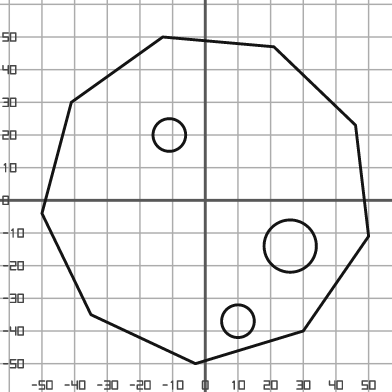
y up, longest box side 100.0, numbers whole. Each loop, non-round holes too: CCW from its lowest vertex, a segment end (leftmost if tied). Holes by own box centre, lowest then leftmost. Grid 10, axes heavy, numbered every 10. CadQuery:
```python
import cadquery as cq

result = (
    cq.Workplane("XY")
    .moveTo(-3.0, -50.0)
    .lineTo(30.0, -40.0)
    .lineTo(50.0, -11.0)
    .lineTo(46.0, 23.0)
    .lineTo(21.0, 47.0)
    .lineTo(-13.0, 50.0)
    .lineTo(-41.0, 30.0)
    .lineTo(-50.0, -4.0)
    .lineTo(-35.0, -35.0)
    .close()
    .moveTo(10.0, -37.0)
    .circle(5.0)
    .moveTo(26.0, -14.0)
    .circle(8.0)
    .moveTo(-11.0, 20.0)
    .circle(5.0)
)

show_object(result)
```